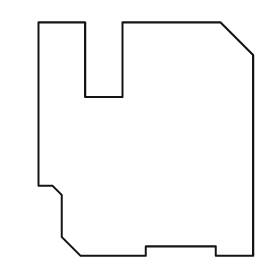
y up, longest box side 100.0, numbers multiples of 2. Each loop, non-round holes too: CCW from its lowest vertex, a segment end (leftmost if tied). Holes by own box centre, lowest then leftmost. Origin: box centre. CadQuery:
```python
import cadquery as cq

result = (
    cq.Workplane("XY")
    .moveTo(-28.0, -50.0)
    .lineTo(0.0, -50.0)
    .lineTo(0.0, -46.0)
    .lineTo(30.0, -46.0)
    .lineTo(30.0, -50.0)
    .lineTo(46.0, -50.0)
    .lineTo(46.0, 36.0)
    .lineTo(32.0, 50.0)
    .lineTo(-10.0, 50.0)
    .lineTo(-10.0, 18.0)
    .lineTo(-26.0, 18.0)
    .lineTo(-26.0, 50.0)
    .lineTo(-46.0, 50.0)
    .lineTo(-46.0, -20.0)
    .lineTo(-40.0, -20.0)
    .lineTo(-36.0, -24.0)
    .lineTo(-36.0, -42.0)
    .close()
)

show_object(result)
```